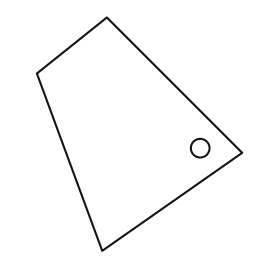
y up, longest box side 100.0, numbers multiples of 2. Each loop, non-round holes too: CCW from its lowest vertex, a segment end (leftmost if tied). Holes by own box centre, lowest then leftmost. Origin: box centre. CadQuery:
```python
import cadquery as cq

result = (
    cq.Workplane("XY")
    .moveTo(-16.0, -50.0)
    .lineTo(44.0, -8.0)
    .lineTo(-14.0, 50.0)
    .lineTo(-44.0, 26.0)
    .close()
    .moveTo(26.0, -6.0)
    .circle(4.0)
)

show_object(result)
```